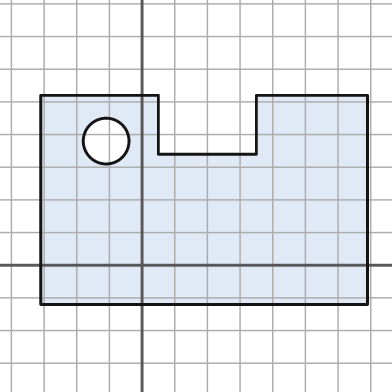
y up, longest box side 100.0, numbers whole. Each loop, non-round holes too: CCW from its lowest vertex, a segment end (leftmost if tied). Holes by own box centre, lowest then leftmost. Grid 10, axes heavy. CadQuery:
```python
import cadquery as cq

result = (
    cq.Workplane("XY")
    .moveTo(-31.0, -12.0)
    .lineTo(69.0, -12.0)
    .lineTo(69.0, 52.0)
    .lineTo(35.0, 52.0)
    .lineTo(35.0, 34.0)
    .lineTo(5.0, 34.0)
    .lineTo(5.0, 52.0)
    .lineTo(-31.0, 52.0)
    .close()
    .moveTo(-11.0, 38.0)
    .circle(7.0)
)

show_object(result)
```